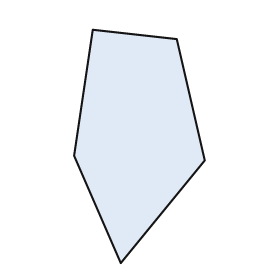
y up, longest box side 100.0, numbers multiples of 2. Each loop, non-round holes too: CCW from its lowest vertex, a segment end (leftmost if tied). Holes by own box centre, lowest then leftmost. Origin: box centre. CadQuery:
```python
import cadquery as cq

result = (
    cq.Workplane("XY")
    .moveTo(-8.0, -50.0)
    .lineTo(28.0, -6.0)
    .lineTo(16.0, 46.0)
    .lineTo(-20.0, 50.0)
    .lineTo(-28.0, -4.0)
    .close()
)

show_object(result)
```